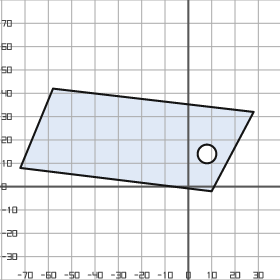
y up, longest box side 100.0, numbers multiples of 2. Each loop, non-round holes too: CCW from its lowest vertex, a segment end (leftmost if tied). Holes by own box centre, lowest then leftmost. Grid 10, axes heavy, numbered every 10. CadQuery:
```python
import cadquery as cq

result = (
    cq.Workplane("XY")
    .moveTo(10.0, -2.0)
    .lineTo(28.0, 32.0)
    .lineTo(-58.0, 42.0)
    .lineTo(-72.0, 8.0)
    .close()
    .moveTo(8.0, 14.0)
    .circle(4.0)
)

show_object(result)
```